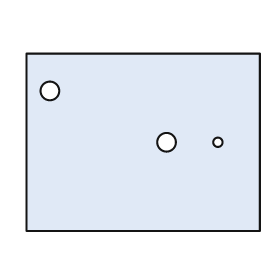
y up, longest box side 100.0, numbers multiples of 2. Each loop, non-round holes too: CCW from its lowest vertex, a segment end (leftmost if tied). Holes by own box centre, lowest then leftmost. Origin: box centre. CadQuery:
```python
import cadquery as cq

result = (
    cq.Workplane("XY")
    .moveTo(-50.0, -38.0)
    .lineTo(50.0, -38.0)
    .lineTo(50.0, 38.0)
    .lineTo(-50.0, 38.0)
    .close()
    .moveTo(10.0, 0.0)
    .circle(4.0)
    .moveTo(32.0, 0.0)
    .circle(2.0)
    .moveTo(-40.0, 22.0)
    .circle(4.0)
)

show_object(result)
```